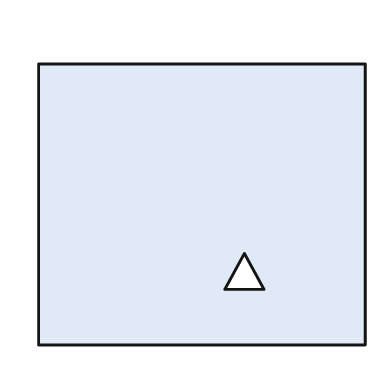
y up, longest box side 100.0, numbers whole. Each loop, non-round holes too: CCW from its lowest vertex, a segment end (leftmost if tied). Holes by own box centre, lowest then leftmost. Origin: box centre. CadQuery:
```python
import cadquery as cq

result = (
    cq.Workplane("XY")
    .moveTo(-50.0, -43.0)
    .lineTo(50.0, -43.0)
    .lineTo(50.0, 43.0)
    .lineTo(-50.0, 43.0)
    .close()
    .moveTo(7.0, -26.0)
    .lineTo(19.0, -26.0)
    .lineTo(13.0, -15.0)
    .close()
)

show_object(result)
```